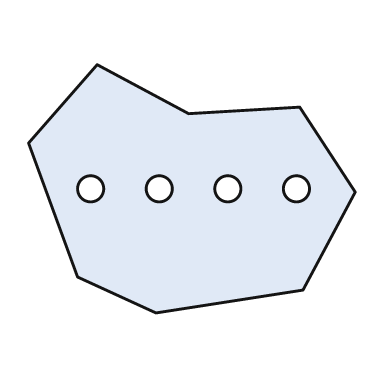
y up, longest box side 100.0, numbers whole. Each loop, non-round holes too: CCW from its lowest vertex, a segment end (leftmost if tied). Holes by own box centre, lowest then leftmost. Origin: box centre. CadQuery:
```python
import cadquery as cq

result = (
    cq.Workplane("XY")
    .moveTo(-11.0, -38.0)
    .lineTo(34.0, -31.0)
    .lineTo(50.0, -1.0)
    .lineTo(33.0, 25.0)
    .lineTo(-1.0, 23.0)
    .lineTo(-29.0, 38.0)
    .lineTo(-50.0, 14.0)
    .lineTo(-35.0, -27.0)
    .close()
    .moveTo(-31.0, 0.0)
    .circle(4.0)
    .moveTo(-10.0, 0.0)
    .circle(4.0)
    .moveTo(11.0, 0.0)
    .circle(4.0)
    .moveTo(32.0, 0.0)
    .circle(4.0)
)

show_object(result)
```